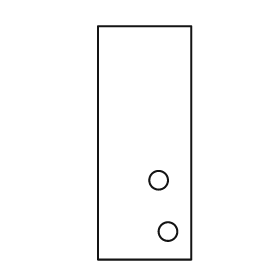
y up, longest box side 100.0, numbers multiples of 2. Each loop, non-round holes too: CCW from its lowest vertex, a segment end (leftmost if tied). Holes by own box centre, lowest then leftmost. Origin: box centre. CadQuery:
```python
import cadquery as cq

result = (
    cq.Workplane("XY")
    .moveTo(-20.0, -50.0)
    .lineTo(20.0, -50.0)
    .lineTo(20.0, 50.0)
    .lineTo(-20.0, 50.0)
    .close()
    .moveTo(10.0, -38.0)
    .circle(4.0)
    .moveTo(6.0, -16.0)
    .circle(4.0)
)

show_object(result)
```